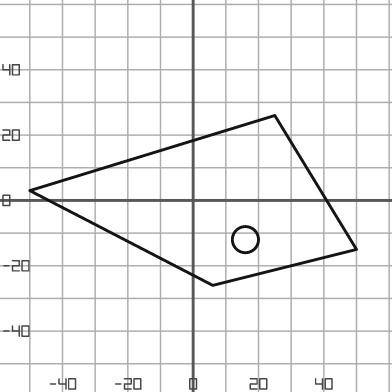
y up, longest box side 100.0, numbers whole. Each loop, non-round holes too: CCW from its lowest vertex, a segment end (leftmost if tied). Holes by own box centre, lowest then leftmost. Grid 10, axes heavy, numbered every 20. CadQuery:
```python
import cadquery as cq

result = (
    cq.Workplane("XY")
    .moveTo(6.0, -26.0)
    .lineTo(50.0, -15.0)
    .lineTo(25.0, 26.0)
    .lineTo(-50.0, 3.0)
    .close()
    .moveTo(16.0, -12.0)
    .circle(4.0)
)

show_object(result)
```